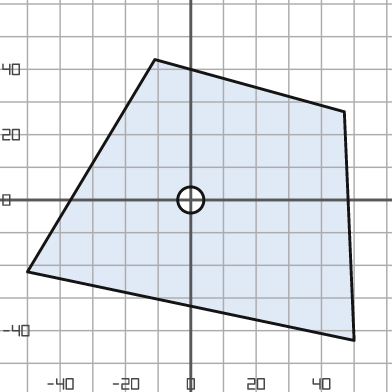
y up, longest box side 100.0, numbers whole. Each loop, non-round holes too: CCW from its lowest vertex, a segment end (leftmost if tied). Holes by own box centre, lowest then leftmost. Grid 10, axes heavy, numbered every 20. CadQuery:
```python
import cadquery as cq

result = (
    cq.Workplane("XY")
    .moveTo(50.0, -43.0)
    .lineTo(47.0, 27.0)
    .lineTo(-11.0, 43.0)
    .lineTo(-50.0, -22.0)
    .close()
    .moveTo(0.0, 0.0)
    .circle(4.0)
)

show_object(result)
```